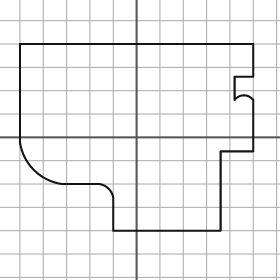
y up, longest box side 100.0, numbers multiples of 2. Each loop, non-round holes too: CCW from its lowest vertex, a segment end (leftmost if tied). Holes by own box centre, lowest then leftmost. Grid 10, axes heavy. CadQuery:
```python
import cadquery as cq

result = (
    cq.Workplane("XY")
    .moveTo(-10.0, -40.0)
    .lineTo(36.0, -40.0)
    .lineTo(36.0, -6.0)
    .lineTo(50.0, -6.0)
    .lineTo(50.0, 16.0)
    .threePointArc((46.0, 18.0), (42.0, 16.0))
    .lineTo(42.0, 26.0)
    .lineTo(50.0, 26.0)
    .lineTo(50.0, 40.0)
    .lineTo(-50.0, 40.0)
    .lineTo(-50.0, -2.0)
    .threePointArc((-44.0, -14.0), (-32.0, -20.0))
    .lineTo(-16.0, -20.0)
    .threePointArc((-12.0, -22.0), (-10.0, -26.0))
    .close()
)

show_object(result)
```